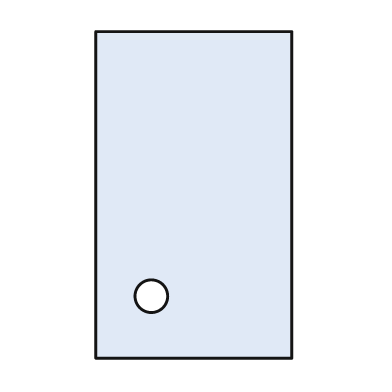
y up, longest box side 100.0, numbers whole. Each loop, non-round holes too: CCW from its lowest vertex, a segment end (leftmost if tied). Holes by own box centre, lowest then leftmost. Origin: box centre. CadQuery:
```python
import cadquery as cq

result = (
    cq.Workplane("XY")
    .moveTo(-30.0, -50.0)
    .lineTo(30.0, -50.0)
    .lineTo(30.0, 50.0)
    .lineTo(-30.0, 50.0)
    .close()
    .moveTo(-13.0, -31.0)
    .circle(5.0)
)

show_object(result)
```